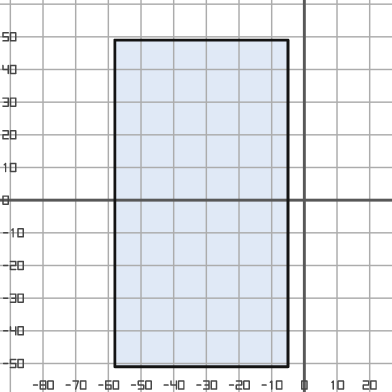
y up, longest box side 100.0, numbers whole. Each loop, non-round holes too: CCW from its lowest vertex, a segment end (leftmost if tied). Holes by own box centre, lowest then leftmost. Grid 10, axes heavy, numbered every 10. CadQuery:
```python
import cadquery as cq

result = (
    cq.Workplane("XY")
    .moveTo(-58.0, -51.0)
    .lineTo(-5.0, -51.0)
    .lineTo(-5.0, 49.0)
    .lineTo(-58.0, 49.0)
    .close()
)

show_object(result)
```